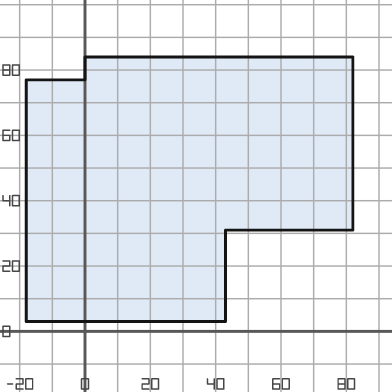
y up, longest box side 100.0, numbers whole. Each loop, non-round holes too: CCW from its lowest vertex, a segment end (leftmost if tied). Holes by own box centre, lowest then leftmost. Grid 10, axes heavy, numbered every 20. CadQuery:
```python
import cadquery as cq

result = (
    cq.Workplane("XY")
    .moveTo(-18.0, 3.0)
    .lineTo(43.0, 3.0)
    .lineTo(43.0, 31.0)
    .lineTo(82.0, 31.0)
    .lineTo(82.0, 84.0)
    .lineTo(0.0, 84.0)
    .lineTo(0.0, 77.0)
    .lineTo(-18.0, 77.0)
    .close()
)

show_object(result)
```